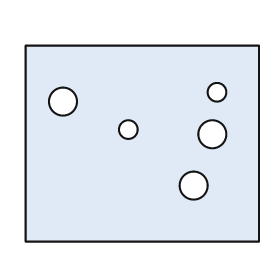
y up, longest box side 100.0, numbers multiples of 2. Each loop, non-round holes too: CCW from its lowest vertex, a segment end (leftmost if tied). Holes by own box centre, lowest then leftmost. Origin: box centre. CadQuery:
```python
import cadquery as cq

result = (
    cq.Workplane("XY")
    .moveTo(-50.0, -42.0)
    .lineTo(50.0, -42.0)
    .lineTo(50.0, 42.0)
    .lineTo(-50.0, 42.0)
    .close()
    .moveTo(22.0, -18.0)
    .circle(6.0)
    .moveTo(30.0, 4.0)
    .circle(6.0)
    .moveTo(-6.0, 6.0)
    .circle(4.0)
    .moveTo(-34.0, 18.0)
    .circle(6.0)
    .moveTo(32.0, 22.0)
    .circle(4.0)
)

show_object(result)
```